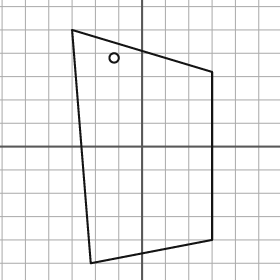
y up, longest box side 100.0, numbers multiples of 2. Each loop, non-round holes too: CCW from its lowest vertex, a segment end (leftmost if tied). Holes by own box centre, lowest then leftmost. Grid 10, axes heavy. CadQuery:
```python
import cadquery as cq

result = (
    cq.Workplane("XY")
    .moveTo(-22.0, -50.0)
    .lineTo(30.0, -40.0)
    .lineTo(30.0, 32.0)
    .lineTo(-30.0, 50.0)
    .close()
    .moveTo(-12.0, 38.0)
    .circle(2.0)
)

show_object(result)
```